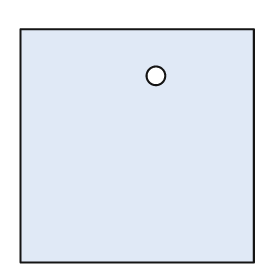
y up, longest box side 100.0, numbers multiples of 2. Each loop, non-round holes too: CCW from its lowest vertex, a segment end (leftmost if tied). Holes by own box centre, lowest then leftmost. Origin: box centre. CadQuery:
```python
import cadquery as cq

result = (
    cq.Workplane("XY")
    .moveTo(-50.0, -50.0)
    .lineTo(50.0, -50.0)
    .lineTo(50.0, 50.0)
    .lineTo(-50.0, 50.0)
    .close()
    .moveTo(8.0, 30.0)
    .circle(4.0)
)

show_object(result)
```